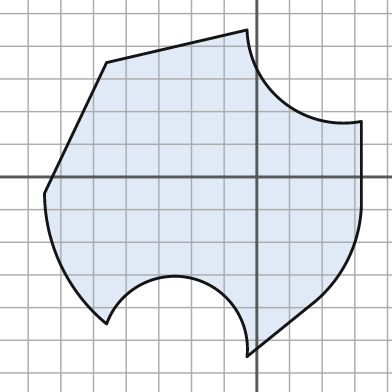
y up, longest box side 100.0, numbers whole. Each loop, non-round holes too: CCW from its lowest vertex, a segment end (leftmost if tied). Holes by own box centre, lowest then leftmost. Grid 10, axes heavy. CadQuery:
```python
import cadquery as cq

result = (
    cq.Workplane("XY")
    .moveTo(-3.0, -55.0)
    .lineTo(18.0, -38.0)
    .threePointArc((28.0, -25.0), (32.0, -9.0))
    .lineTo(32.0, 17.0)
    .threePointArc((8.0, 23.0), (-3.0, 45.0))
    .lineTo(-46.0, 35.0)
    .lineTo(-65.0, -5.0)
    .threePointArc((-60.0, -27.0), (-46.0, -45.0))
    .threePointArc((-20.0, -31.0), (-3.0, -55.0))
    .close()
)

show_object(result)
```